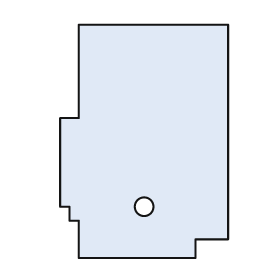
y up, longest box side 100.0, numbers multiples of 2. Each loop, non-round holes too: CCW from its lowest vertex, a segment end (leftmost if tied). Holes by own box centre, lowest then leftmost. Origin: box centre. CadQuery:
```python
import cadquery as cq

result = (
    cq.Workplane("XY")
    .moveTo(-28.0, -50.0)
    .lineTo(22.0, -50.0)
    .lineTo(22.0, -42.0)
    .lineTo(36.0, -42.0)
    .lineTo(36.0, 50.0)
    .lineTo(-28.0, 50.0)
    .lineTo(-28.0, 10.0)
    .lineTo(-36.0, 10.0)
    .lineTo(-36.0, -28.0)
    .lineTo(-32.0, -28.0)
    .lineTo(-32.0, -34.0)
    .lineTo(-28.0, -34.0)
    .close()
    .moveTo(0.0, -28.0)
    .circle(4.0)
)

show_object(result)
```